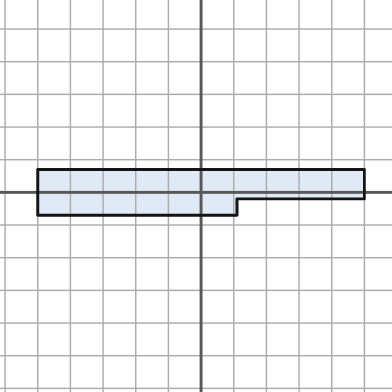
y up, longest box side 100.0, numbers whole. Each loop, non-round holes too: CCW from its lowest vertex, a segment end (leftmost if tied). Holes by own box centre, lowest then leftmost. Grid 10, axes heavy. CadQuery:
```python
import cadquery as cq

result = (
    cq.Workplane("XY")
    .moveTo(-50.0, -7.0)
    .lineTo(11.0, -7.0)
    .lineTo(11.0, -2.0)
    .lineTo(50.0, -2.0)
    .lineTo(50.0, 7.0)
    .lineTo(-50.0, 7.0)
    .close()
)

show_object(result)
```